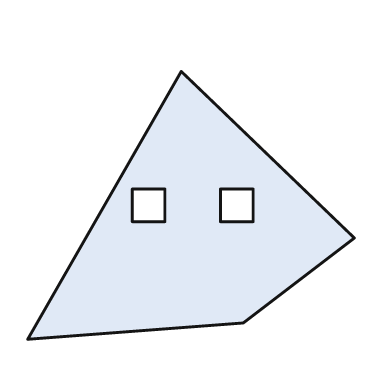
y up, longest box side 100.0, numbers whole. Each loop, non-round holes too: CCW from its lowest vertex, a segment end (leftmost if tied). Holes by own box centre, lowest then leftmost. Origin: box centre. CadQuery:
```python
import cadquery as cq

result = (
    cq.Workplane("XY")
    .moveTo(-50.0, -41.0)
    .lineTo(16.0, -36.0)
    .lineTo(50.0, -10.0)
    .lineTo(-3.0, 41.0)
    .close()
    .moveTo(-18.0, -5.0)
    .lineTo(-8.0, -5.0)
    .lineTo(-8.0, 5.0)
    .lineTo(-18.0, 5.0)
    .close()
    .moveTo(9.0, -5.0)
    .lineTo(19.0, -5.0)
    .lineTo(19.0, 5.0)
    .lineTo(9.0, 5.0)
    .close()
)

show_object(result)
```